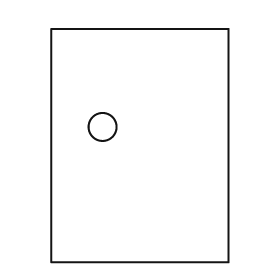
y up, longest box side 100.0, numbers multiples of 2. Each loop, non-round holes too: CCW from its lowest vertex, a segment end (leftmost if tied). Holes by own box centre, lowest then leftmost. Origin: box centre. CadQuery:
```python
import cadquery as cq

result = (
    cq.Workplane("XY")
    .moveTo(-38.0, -50.0)
    .lineTo(38.0, -50.0)
    .lineTo(38.0, 50.0)
    .lineTo(-38.0, 50.0)
    .close()
    .moveTo(-16.0, 8.0)
    .circle(6.0)
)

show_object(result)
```